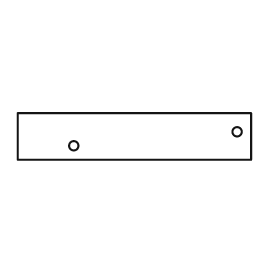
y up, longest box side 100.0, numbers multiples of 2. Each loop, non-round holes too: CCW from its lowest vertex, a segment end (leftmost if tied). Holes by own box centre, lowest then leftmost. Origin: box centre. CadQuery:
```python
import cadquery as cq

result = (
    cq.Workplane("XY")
    .moveTo(-50.0, -10.0)
    .lineTo(50.0, -10.0)
    .lineTo(50.0, 10.0)
    .lineTo(-50.0, 10.0)
    .close()
    .moveTo(-26.0, -4.0)
    .circle(2.0)
    .moveTo(44.0, 2.0)
    .circle(2.0)
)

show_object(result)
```